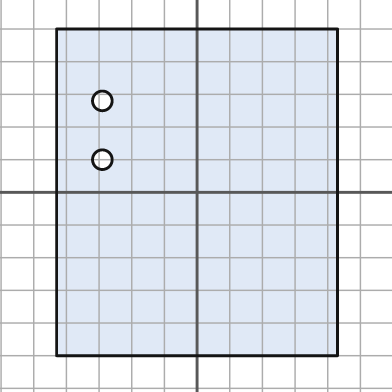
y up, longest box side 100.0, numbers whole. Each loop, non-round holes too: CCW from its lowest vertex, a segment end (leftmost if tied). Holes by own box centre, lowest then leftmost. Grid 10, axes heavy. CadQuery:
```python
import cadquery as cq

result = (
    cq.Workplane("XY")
    .moveTo(-43.0, -50.0)
    .lineTo(43.0, -50.0)
    .lineTo(43.0, 50.0)
    .lineTo(-43.0, 50.0)
    .close()
    .moveTo(-29.0, 10.0)
    .circle(3.0)
    .moveTo(-29.0, 28.0)
    .circle(3.0)
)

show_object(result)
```